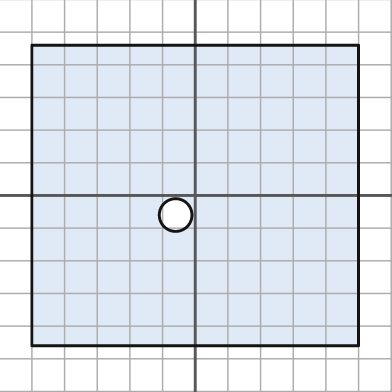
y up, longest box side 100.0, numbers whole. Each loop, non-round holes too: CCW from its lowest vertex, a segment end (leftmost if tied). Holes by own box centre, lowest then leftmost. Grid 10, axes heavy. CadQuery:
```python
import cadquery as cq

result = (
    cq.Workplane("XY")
    .moveTo(-50.0, -46.0)
    .lineTo(50.0, -46.0)
    .lineTo(50.0, 46.0)
    .lineTo(-50.0, 46.0)
    .close()
    .moveTo(-6.0, -6.0)
    .circle(5.0)
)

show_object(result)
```